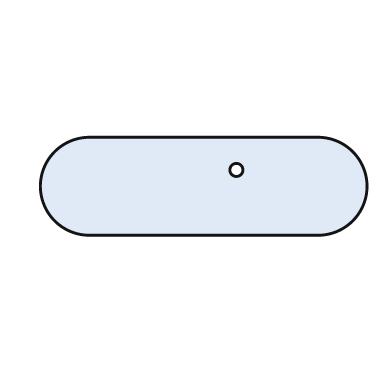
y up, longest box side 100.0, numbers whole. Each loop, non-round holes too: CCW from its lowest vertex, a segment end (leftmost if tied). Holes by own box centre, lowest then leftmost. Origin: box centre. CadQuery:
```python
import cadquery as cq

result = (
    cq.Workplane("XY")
    .moveTo(-35.0, -15.0)
    .lineTo(35.0, -15.0)
    .threePointArc((50.0, 0.0), (35.0, 15.0))
    .lineTo(-35.0, 15.0)
    .threePointArc((-50.0, 0.0), (-35.0, -15.0))
    .close()
    .moveTo(10.0, 5.0)
    .circle(2.0)
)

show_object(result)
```